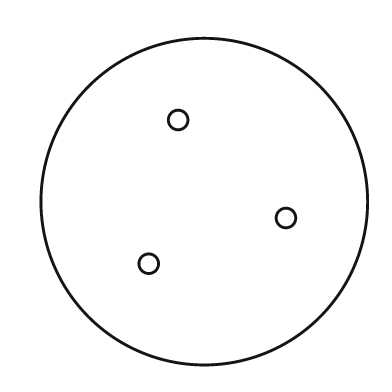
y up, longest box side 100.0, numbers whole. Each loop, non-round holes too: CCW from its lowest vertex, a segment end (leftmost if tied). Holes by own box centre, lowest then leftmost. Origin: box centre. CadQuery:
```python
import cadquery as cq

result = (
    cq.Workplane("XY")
    .moveTo(0.0, 0.0)
    .circle(50.0)
    .moveTo(-17.0, -19.0)
    .circle(3.0)
    .moveTo(25.0, -5.0)
    .circle(3.0)
    .moveTo(-8.0, 25.0)
    .circle(3.0)
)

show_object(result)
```